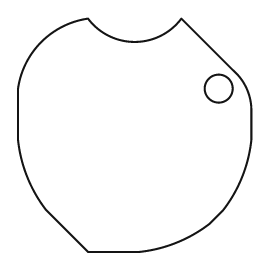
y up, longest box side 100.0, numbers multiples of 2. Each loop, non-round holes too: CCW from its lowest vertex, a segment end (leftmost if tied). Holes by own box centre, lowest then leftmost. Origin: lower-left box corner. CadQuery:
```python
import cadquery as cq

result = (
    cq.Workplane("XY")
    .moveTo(30.0, 0.0)
    .lineTo(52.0, 0.0)
    .threePointArc((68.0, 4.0), (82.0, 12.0))
    .lineTo(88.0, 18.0)
    .threePointArc((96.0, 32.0), (100.0, 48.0))
    .lineTo(100.0, 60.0)
    .threePointArc((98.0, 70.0), (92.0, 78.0))
    .lineTo(70.0, 100.0)
    .threePointArc((50.0, 90.0), (30.0, 100.0))
    .threePointArc((10.0, 90.0), (0.0, 70.0))
    .lineTo(0.0, 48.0)
    .threePointArc((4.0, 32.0), (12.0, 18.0))
    .close()
    .moveTo(86.0, 70.0)
    .circle(6.0)
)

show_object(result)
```